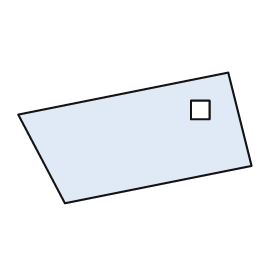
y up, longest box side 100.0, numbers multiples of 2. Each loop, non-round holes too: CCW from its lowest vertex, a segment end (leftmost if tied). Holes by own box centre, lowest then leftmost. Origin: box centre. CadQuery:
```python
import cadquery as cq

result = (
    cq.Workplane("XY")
    .moveTo(-30.0, -28.0)
    .lineTo(50.0, -12.0)
    .lineTo(40.0, 28.0)
    .lineTo(-50.0, 10.0)
    .close()
    .moveTo(24.0, 8.0)
    .lineTo(32.0, 8.0)
    .lineTo(32.0, 16.0)
    .lineTo(24.0, 16.0)
    .close()
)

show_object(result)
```